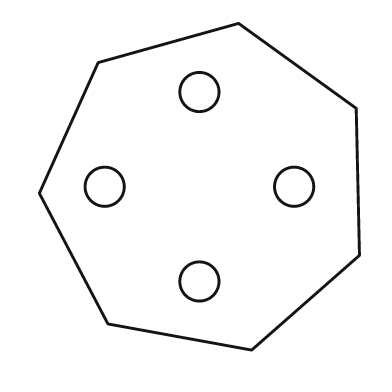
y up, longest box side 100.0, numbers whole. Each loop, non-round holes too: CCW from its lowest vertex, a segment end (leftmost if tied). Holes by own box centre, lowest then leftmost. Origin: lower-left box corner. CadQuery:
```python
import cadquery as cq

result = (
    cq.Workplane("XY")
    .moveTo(65.0, 0.0)
    .lineTo(98.0, 29.0)
    .lineTo(97.0, 74.0)
    .lineTo(61.0, 100.0)
    .lineTo(18.0, 88.0)
    .lineTo(0.0, 48.0)
    .lineTo(21.0, 8.0)
    .close()
    .moveTo(49.0, 21.0)
    .circle(6.0)
    .moveTo(20.0, 50.0)
    .circle(6.0)
    .moveTo(78.0, 50.0)
    .circle(6.0)
    .moveTo(49.0, 79.0)
    .circle(6.0)
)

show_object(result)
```